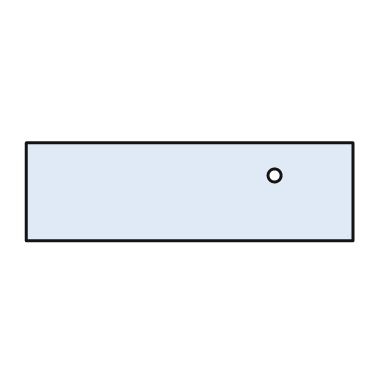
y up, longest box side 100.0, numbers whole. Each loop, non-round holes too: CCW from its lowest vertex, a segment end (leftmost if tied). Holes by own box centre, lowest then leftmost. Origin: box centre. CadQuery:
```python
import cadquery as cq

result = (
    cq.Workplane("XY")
    .moveTo(-50.0, -15.0)
    .lineTo(50.0, -15.0)
    .lineTo(50.0, 15.0)
    .lineTo(-50.0, 15.0)
    .close()
    .moveTo(26.0, 5.0)
    .circle(2.0)
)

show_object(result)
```